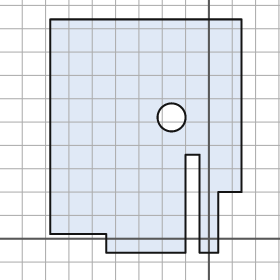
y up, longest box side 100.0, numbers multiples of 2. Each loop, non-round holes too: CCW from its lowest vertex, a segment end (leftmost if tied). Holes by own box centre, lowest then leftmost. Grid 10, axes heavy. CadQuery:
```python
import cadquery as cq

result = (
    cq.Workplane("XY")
    .moveTo(-44.0, -6.0)
    .lineTo(-10.0, -6.0)
    .lineTo(-10.0, 36.0)
    .lineTo(-4.0, 36.0)
    .lineTo(-4.0, -6.0)
    .lineTo(4.0, -6.0)
    .lineTo(4.0, 20.0)
    .lineTo(14.0, 20.0)
    .lineTo(14.0, 94.0)
    .lineTo(-68.0, 94.0)
    .lineTo(-68.0, 2.0)
    .lineTo(-44.0, 2.0)
    .close()
    .moveTo(-16.0, 52.0)
    .circle(6.0)
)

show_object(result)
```